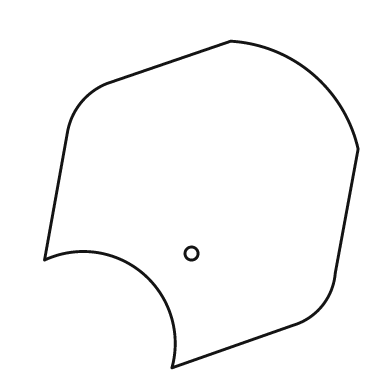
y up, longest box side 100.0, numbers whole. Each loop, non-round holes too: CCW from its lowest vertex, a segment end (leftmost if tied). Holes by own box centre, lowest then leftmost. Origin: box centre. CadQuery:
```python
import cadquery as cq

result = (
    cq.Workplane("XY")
    .moveTo(-9.0, -50.0)
    .lineTo(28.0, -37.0)
    .threePointArc((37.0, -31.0), (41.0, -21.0))
    .lineTo(48.0, 17.0)
    .threePointArc((34.0, 40.0), (9.0, 50.0))
    .lineTo(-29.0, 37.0)
    .threePointArc((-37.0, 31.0), (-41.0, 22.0))
    .lineTo(-48.0, -17.0)
    .threePointArc((-18.0, -21.0), (-9.0, -50.0))
    .close()
    .moveTo(-3.0, -15.0)
    .circle(2.0)
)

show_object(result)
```